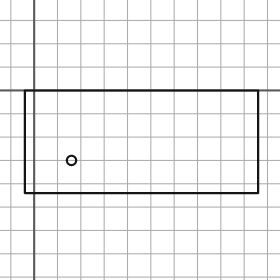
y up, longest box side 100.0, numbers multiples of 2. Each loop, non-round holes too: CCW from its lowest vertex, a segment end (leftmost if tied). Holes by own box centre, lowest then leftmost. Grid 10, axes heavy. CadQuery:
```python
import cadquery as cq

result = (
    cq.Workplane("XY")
    .moveTo(-4.0, -44.0)
    .lineTo(96.0, -44.0)
    .lineTo(96.0, 0.0)
    .lineTo(-4.0, 0.0)
    .close()
    .moveTo(16.0, -30.0)
    .circle(2.0)
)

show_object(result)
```